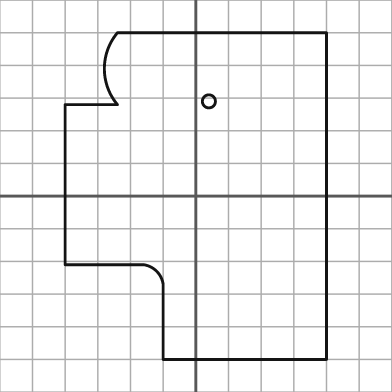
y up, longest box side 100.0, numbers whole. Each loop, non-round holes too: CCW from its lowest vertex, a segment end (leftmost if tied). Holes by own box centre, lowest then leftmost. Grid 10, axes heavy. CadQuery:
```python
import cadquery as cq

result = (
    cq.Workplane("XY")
    .moveTo(-10.0, -50.0)
    .lineTo(40.0, -50.0)
    .lineTo(40.0, 50.0)
    .lineTo(-24.0, 50.0)
    .threePointArc((-28.0, 39.0), (-24.0, 28.0))
    .lineTo(-40.0, 28.0)
    .lineTo(-40.0, -21.0)
    .lineTo(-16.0, -21.0)
    .threePointArc((-12.0, -23.0), (-10.0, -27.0))
    .close()
    .moveTo(4.0, 29.0)
    .circle(2.0)
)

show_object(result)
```